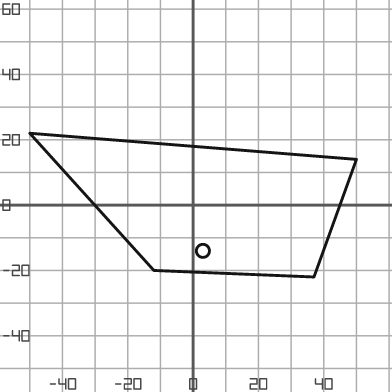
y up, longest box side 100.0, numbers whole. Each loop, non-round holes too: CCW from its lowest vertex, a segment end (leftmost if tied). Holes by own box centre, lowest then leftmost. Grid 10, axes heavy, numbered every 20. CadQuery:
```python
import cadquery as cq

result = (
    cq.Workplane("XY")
    .moveTo(37.0, -22.0)
    .lineTo(50.0, 14.0)
    .lineTo(-50.0, 22.0)
    .lineTo(-12.0, -20.0)
    .close()
    .moveTo(3.0, -14.0)
    .circle(2.0)
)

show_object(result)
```